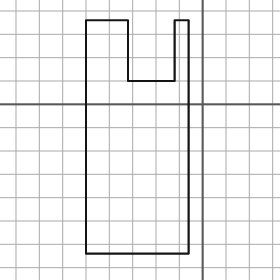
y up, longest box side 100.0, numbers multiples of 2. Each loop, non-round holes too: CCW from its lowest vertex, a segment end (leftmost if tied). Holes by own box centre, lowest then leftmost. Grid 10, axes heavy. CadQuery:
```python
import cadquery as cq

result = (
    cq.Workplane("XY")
    .moveTo(-50.0, -64.0)
    .lineTo(-6.0, -64.0)
    .lineTo(-6.0, 36.0)
    .lineTo(-12.0, 36.0)
    .lineTo(-12.0, 10.0)
    .lineTo(-32.0, 10.0)
    .lineTo(-32.0, 36.0)
    .lineTo(-50.0, 36.0)
    .close()
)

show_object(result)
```